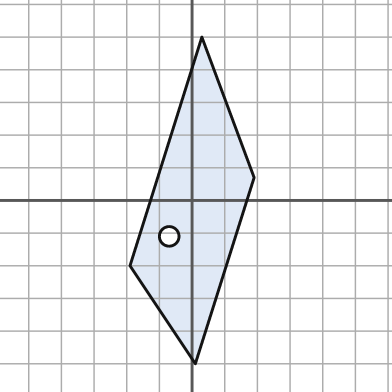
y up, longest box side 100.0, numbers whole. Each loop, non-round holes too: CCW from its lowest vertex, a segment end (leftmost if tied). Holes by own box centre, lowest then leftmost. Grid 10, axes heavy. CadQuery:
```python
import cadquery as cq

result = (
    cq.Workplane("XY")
    .moveTo(1.0, -50.0)
    .lineTo(19.0, 7.0)
    .lineTo(3.0, 50.0)
    .lineTo(-19.0, -20.0)
    .close()
    .moveTo(-7.0, -11.0)
    .circle(3.0)
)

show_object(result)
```